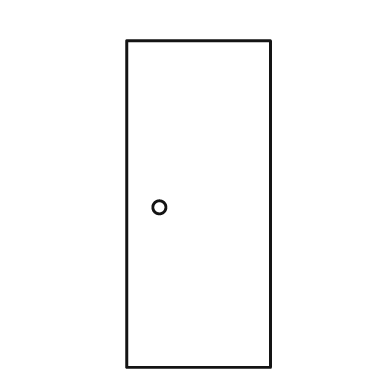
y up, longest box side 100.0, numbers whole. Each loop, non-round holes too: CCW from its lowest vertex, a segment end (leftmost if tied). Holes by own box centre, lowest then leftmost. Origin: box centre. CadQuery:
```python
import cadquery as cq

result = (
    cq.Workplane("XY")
    .moveTo(-22.0, -50.0)
    .lineTo(22.0, -50.0)
    .lineTo(22.0, 50.0)
    .lineTo(-22.0, 50.0)
    .close()
    .moveTo(-12.0, -1.0)
    .circle(2.0)
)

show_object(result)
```